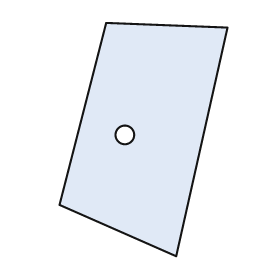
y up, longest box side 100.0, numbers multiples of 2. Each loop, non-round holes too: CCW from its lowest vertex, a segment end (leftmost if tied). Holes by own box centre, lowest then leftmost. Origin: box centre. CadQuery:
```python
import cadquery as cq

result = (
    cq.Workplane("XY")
    .moveTo(14.0, -50.0)
    .lineTo(36.0, 48.0)
    .lineTo(-16.0, 50.0)
    .lineTo(-36.0, -28.0)
    .close()
    .moveTo(-8.0, 2.0)
    .circle(4.0)
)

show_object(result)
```